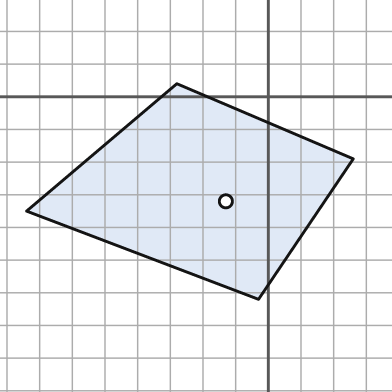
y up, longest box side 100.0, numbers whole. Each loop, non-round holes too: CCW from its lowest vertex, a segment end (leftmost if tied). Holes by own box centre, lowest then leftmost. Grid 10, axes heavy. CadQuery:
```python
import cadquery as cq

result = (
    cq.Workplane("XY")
    .moveTo(-3.0, -62.0)
    .lineTo(26.0, -19.0)
    .lineTo(-28.0, 4.0)
    .lineTo(-74.0, -35.0)
    .close()
    .moveTo(-13.0, -32.0)
    .circle(2.0)
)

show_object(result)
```